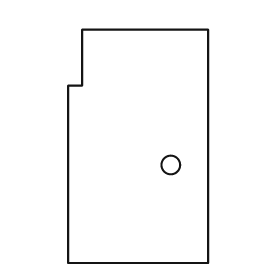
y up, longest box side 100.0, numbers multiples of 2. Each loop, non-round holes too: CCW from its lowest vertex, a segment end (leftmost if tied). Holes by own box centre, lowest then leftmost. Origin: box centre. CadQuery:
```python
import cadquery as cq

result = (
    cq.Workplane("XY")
    .moveTo(-30.0, -50.0)
    .lineTo(30.0, -50.0)
    .lineTo(30.0, 50.0)
    .lineTo(-24.0, 50.0)
    .lineTo(-24.0, 26.0)
    .lineTo(-30.0, 26.0)
    .close()
    .moveTo(14.0, -8.0)
    .circle(4.0)
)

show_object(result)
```